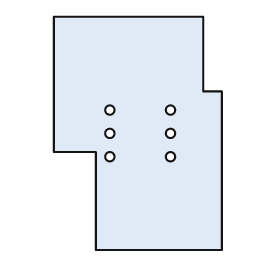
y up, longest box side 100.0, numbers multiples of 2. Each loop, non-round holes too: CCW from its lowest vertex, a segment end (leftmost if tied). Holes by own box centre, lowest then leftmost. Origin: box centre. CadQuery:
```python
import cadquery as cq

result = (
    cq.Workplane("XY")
    .moveTo(-18.0, -50.0)
    .lineTo(36.0, -50.0)
    .lineTo(36.0, 18.0)
    .lineTo(28.0, 18.0)
    .lineTo(28.0, 50.0)
    .lineTo(-36.0, 50.0)
    .lineTo(-36.0, -8.0)
    .lineTo(-18.0, -8.0)
    .close()
    .moveTo(-12.0, -10.0)
    .circle(2.0)
    .moveTo(14.0, -10.0)
    .circle(2.0)
    .moveTo(-12.0, 0.0)
    .circle(2.0)
    .moveTo(14.0, 0.0)
    .circle(2.0)
    .moveTo(-12.0, 10.0)
    .circle(2.0)
    .moveTo(14.0, 10.0)
    .circle(2.0)
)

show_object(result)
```